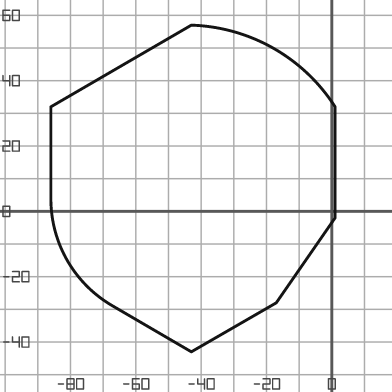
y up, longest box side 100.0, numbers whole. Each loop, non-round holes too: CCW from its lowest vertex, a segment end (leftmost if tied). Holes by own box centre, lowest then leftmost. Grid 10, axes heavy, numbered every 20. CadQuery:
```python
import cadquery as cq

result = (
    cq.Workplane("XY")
    .moveTo(-43.0, -43.0)
    .lineTo(-17.0, -28.0)
    .lineTo(1.0, -2.0)
    .lineTo(1.0, 32.0)
    .threePointArc((-18.0, 50.0), (-43.0, 57.0))
    .lineTo(-86.0, 32.0)
    .lineTo(-86.0, 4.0)
    .threePointArc((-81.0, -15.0), (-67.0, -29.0))
    .close()
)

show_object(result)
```